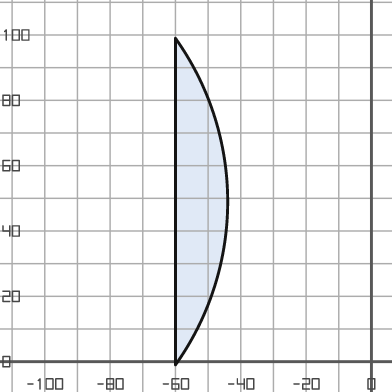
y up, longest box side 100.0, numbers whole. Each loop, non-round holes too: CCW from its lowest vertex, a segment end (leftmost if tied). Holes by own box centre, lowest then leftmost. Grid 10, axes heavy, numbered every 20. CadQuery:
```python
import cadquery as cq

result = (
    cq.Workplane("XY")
    .moveTo(-60.0, -1.0)
    .threePointArc((-44.0, 49.0), (-60.0, 99.0))
    .close()
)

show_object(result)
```